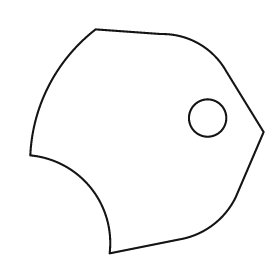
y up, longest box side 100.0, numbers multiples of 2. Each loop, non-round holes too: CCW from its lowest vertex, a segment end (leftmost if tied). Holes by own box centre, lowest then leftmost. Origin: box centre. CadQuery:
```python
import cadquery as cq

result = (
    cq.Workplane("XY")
    .moveTo(-16.0, -48.0)
    .lineTo(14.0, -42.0)
    .threePointArc((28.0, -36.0), (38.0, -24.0))
    .lineTo(50.0, 4.0)
    .lineTo(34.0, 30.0)
    .threePointArc((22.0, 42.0), (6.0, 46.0))
    .lineTo(-22.0, 48.0)
    .threePointArc((-42.0, 24.0), (-50.0, -6.0))
    .threePointArc((-24.0, -20.0), (-16.0, -48.0))
    .close()
    .moveTo(26.0, 10.0)
    .circle(8.0)
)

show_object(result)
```